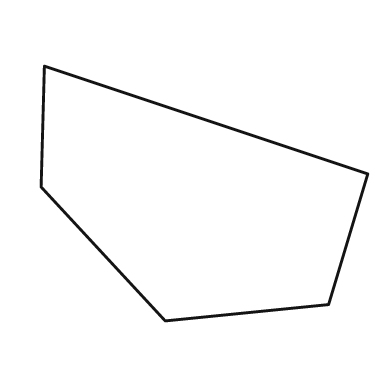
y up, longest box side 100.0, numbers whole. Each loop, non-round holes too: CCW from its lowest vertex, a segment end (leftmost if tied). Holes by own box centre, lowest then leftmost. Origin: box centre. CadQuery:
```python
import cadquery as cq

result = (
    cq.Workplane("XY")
    .moveTo(-12.0, -39.0)
    .lineTo(38.0, -34.0)
    .lineTo(50.0, 6.0)
    .lineTo(-49.0, 39.0)
    .lineTo(-50.0, 2.0)
    .close()
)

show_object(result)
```